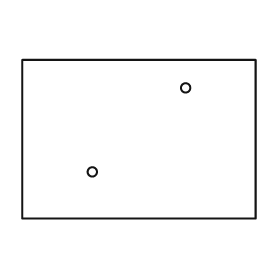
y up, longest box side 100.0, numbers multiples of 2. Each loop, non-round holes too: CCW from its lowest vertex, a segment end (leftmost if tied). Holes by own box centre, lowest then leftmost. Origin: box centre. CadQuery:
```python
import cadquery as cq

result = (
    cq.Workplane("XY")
    .moveTo(-50.0, -34.0)
    .lineTo(50.0, -34.0)
    .lineTo(50.0, 34.0)
    .lineTo(-50.0, 34.0)
    .close()
    .moveTo(-20.0, -14.0)
    .circle(2.0)
    .moveTo(20.0, 22.0)
    .circle(2.0)
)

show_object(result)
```